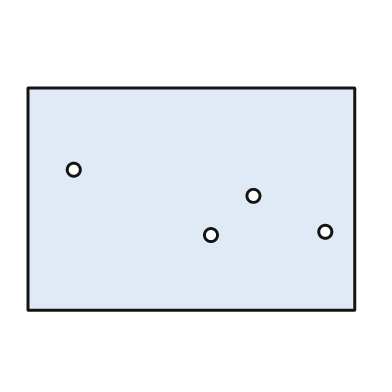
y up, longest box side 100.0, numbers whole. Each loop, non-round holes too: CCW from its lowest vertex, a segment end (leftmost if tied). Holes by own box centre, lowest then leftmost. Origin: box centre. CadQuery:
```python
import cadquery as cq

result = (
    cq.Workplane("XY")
    .moveTo(-50.0, -34.0)
    .lineTo(50.0, -34.0)
    .lineTo(50.0, 34.0)
    .lineTo(-50.0, 34.0)
    .close()
    .moveTo(6.0, -11.0)
    .circle(2.0)
    .moveTo(41.0, -10.0)
    .circle(2.0)
    .moveTo(19.0, 1.0)
    .circle(2.0)
    .moveTo(-36.0, 9.0)
    .circle(2.0)
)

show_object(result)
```